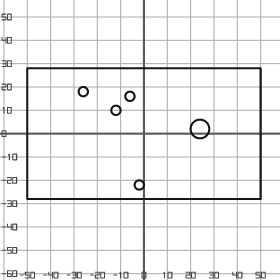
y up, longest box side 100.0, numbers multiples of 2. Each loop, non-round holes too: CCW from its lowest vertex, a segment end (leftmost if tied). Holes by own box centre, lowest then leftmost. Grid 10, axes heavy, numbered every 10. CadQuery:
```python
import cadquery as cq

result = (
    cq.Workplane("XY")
    .moveTo(-50.0, -28.0)
    .lineTo(50.0, -28.0)
    .lineTo(50.0, 28.0)
    .lineTo(-50.0, 28.0)
    .close()
    .moveTo(-2.0, -22.0)
    .circle(2.0)
    .moveTo(24.0, 2.0)
    .circle(4.0)
    .moveTo(-12.0, 10.0)
    .circle(2.0)
    .moveTo(-6.0, 16.0)
    .circle(2.0)
    .moveTo(-26.0, 18.0)
    .circle(2.0)
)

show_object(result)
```